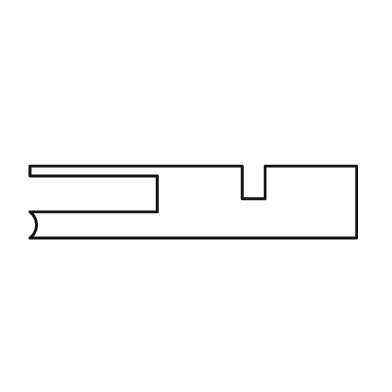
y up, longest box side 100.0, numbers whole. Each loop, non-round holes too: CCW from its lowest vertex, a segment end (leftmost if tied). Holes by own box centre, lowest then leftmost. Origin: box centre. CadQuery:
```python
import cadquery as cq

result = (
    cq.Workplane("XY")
    .moveTo(-50.0, -11.0)
    .lineTo(50.0, -11.0)
    .lineTo(50.0, 11.0)
    .lineTo(22.0, 11.0)
    .lineTo(22.0, 1.0)
    .lineTo(15.0, 1.0)
    .lineTo(15.0, 11.0)
    .lineTo(-50.0, 11.0)
    .lineTo(-50.0, 8.0)
    .lineTo(-11.0, 8.0)
    .lineTo(-11.0, -3.0)
    .lineTo(-50.0, -3.0)
    .threePointArc((-48.0, -7.0), (-50.0, -11.0))
    .close()
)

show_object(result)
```